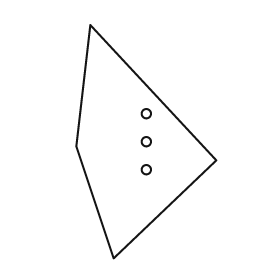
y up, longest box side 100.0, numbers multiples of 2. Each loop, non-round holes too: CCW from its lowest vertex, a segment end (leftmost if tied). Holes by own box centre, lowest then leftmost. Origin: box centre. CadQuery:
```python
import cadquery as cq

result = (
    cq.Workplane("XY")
    .moveTo(-14.0, -50.0)
    .lineTo(30.0, -8.0)
    .lineTo(-24.0, 50.0)
    .lineTo(-30.0, -2.0)
    .close()
    .moveTo(0.0, -12.0)
    .circle(2.0)
    .moveTo(0.0, 0.0)
    .circle(2.0)
    .moveTo(0.0, 12.0)
    .circle(2.0)
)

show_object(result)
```